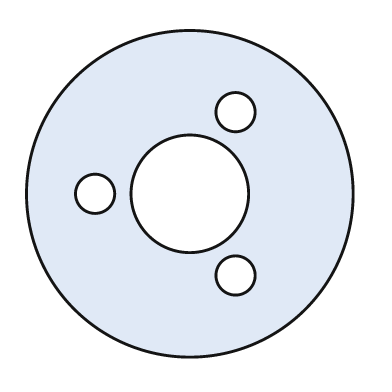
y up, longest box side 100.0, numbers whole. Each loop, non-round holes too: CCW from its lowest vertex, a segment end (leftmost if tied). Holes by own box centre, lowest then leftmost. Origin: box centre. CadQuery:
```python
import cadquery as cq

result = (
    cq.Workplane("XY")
    .moveTo(0.0, 0.0)
    .circle(50.0)
    .moveTo(14.0, -25.0)
    .circle(6.0)
    .moveTo(-29.0, 0.0)
    .circle(6.0)
    .moveTo(0.0, 0.0)
    .circle(18.0)
    .moveTo(14.0, 25.0)
    .circle(6.0)
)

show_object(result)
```